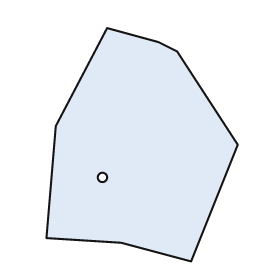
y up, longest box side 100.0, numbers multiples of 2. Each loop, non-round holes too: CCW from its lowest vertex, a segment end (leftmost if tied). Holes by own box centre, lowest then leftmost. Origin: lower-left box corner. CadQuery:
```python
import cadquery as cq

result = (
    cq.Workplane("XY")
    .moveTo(62.0, 0.0)
    .lineTo(82.0, 50.0)
    .lineTo(56.0, 90.0)
    .lineTo(48.0, 94.0)
    .lineTo(26.0, 100.0)
    .lineTo(4.0, 58.0)
    .lineTo(0.0, 10.0)
    .lineTo(32.0, 8.0)
    .close()
    .moveTo(24.0, 36.0)
    .circle(2.0)
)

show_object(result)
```